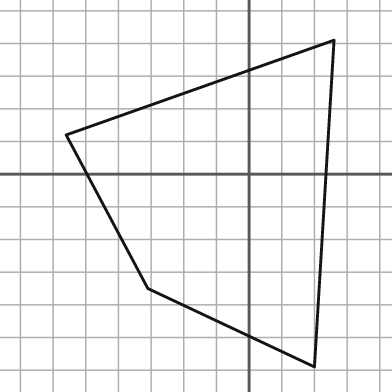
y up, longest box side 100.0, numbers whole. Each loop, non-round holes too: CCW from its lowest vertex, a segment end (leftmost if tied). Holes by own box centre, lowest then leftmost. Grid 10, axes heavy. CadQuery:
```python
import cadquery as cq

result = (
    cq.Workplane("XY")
    .moveTo(20.0, -59.0)
    .lineTo(26.0, 41.0)
    .lineTo(-56.0, 12.0)
    .lineTo(-31.0, -35.0)
    .close()
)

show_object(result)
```